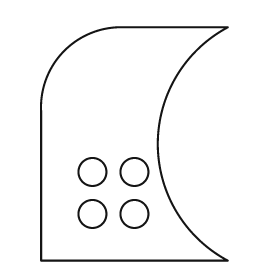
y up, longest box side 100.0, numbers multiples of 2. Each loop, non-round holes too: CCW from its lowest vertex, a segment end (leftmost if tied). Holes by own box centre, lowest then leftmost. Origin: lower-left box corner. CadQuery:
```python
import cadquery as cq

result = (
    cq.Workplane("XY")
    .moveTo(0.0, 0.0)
    .lineTo(80.0, 0.0)
    .threePointArc((50.0, 50.0), (80.0, 100.0))
    .lineTo(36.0, 100.0)
    .threePointArc((10.0, 90.0), (0.0, 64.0))
    .close()
    .moveTo(22.0, 20.0)
    .circle(6.0)
    .moveTo(40.0, 20.0)
    .circle(6.0)
    .moveTo(22.0, 38.0)
    .circle(6.0)
    .moveTo(40.0, 38.0)
    .circle(6.0)
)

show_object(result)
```